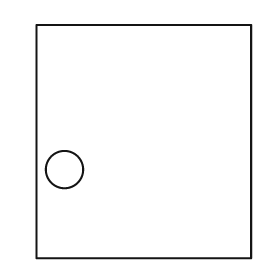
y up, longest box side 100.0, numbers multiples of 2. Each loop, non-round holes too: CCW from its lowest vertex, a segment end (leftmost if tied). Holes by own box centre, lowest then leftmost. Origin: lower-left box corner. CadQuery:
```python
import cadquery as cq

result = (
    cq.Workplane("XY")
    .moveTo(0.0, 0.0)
    .lineTo(92.0, 0.0)
    .lineTo(92.0, 100.0)
    .lineTo(0.0, 100.0)
    .close()
    .moveTo(12.0, 38.0)
    .circle(8.0)
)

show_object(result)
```